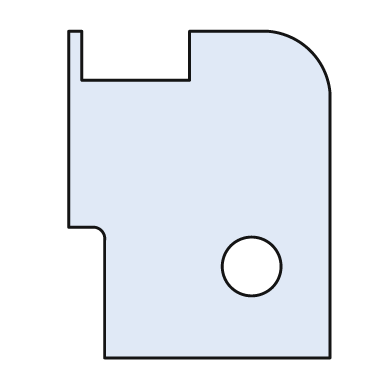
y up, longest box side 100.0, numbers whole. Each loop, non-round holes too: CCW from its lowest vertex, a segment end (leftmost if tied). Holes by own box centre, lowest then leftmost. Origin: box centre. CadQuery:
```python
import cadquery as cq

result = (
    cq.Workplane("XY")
    .moveTo(-29.0, -50.0)
    .lineTo(40.0, -50.0)
    .lineTo(40.0, 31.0)
    .threePointArc((34.0, 44.0), (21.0, 50.0))
    .lineTo(-3.0, 50.0)
    .lineTo(-3.0, 35.0)
    .lineTo(-36.0, 35.0)
    .lineTo(-36.0, 50.0)
    .lineTo(-40.0, 50.0)
    .lineTo(-40.0, -10.0)
    .lineTo(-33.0, -10.0)
    .threePointArc((-30.0, -11.0), (-29.0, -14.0))
    .close()
    .moveTo(16.0, -22.0)
    .circle(9.0)
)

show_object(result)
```